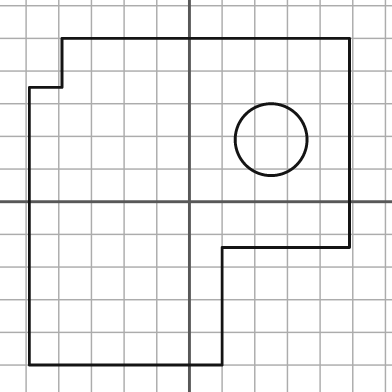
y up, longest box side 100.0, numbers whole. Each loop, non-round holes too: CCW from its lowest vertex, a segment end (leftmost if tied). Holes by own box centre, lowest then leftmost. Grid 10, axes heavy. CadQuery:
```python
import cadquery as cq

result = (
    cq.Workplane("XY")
    .moveTo(-49.0, -50.0)
    .lineTo(10.0, -50.0)
    .lineTo(10.0, -14.0)
    .lineTo(49.0, -14.0)
    .lineTo(49.0, 50.0)
    .lineTo(-39.0, 50.0)
    .lineTo(-39.0, 35.0)
    .lineTo(-49.0, 35.0)
    .close()
    .moveTo(25.0, 19.0)
    .circle(11.0)
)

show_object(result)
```